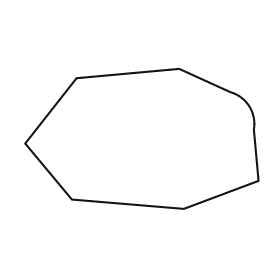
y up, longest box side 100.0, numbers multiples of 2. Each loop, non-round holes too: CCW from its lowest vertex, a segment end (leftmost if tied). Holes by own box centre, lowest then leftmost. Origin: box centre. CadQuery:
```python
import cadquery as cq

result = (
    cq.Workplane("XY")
    .moveTo(18.0, -30.0)
    .lineTo(50.0, -18.0)
    .lineTo(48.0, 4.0)
    .threePointArc((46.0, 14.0), (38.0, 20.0))
    .lineTo(16.0, 30.0)
    .lineTo(-28.0, 26.0)
    .lineTo(-50.0, -2.0)
    .lineTo(-30.0, -26.0)
    .close()
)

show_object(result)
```